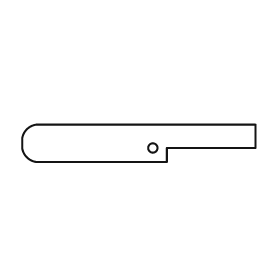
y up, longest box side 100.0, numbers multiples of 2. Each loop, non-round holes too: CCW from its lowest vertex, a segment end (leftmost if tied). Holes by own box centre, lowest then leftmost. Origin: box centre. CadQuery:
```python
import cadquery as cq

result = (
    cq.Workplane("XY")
    .moveTo(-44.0, -8.0)
    .lineTo(12.0, -8.0)
    .lineTo(12.0, -2.0)
    .lineTo(50.0, -2.0)
    .lineTo(50.0, 8.0)
    .lineTo(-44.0, 8.0)
    .threePointArc((-48.0, 6.0), (-50.0, 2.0))
    .lineTo(-50.0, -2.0)
    .threePointArc((-48.0, -6.0), (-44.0, -8.0))
    .close()
    .moveTo(6.0, -2.0)
    .circle(2.0)
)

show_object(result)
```